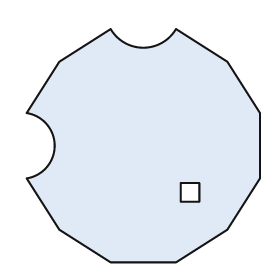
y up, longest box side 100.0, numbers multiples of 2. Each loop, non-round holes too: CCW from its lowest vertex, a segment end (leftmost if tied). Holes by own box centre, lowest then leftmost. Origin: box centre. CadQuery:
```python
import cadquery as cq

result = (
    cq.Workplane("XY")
    .moveTo(-14.0, -50.0)
    .lineTo(14.0, -50.0)
    .lineTo(36.0, -36.0)
    .lineTo(50.0, -14.0)
    .lineTo(50.0, 14.0)
    .lineTo(36.0, 36.0)
    .lineTo(14.0, 50.0)
    .threePointArc((0.0, 42.0), (-14.0, 50.0))
    .lineTo(-36.0, 36.0)
    .lineTo(-50.0, 14.0)
    .threePointArc((-38.0, 0.0), (-50.0, -14.0))
    .lineTo(-36.0, -36.0)
    .close()
    .moveTo(16.0, -24.0)
    .lineTo(24.0, -24.0)
    .lineTo(24.0, -16.0)
    .lineTo(16.0, -16.0)
    .close()
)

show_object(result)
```